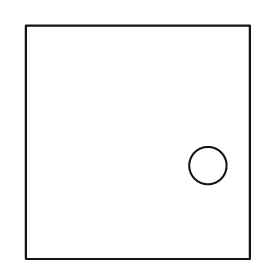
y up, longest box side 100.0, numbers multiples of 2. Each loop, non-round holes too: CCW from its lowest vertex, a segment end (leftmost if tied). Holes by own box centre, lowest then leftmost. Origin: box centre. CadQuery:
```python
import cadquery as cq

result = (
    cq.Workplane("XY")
    .moveTo(-48.0, -50.0)
    .lineTo(48.0, -50.0)
    .lineTo(48.0, 50.0)
    .lineTo(-48.0, 50.0)
    .close()
    .moveTo(30.0, -10.0)
    .circle(8.0)
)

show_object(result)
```